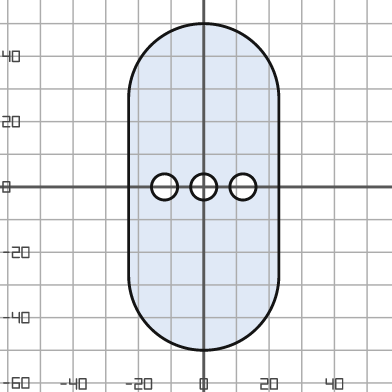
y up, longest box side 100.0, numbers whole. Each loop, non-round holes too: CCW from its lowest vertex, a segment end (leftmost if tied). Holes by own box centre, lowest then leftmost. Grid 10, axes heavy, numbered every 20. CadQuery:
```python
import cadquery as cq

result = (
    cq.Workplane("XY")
    .moveTo(-23.0, -27.0)
    .threePointArc((0.0, -50.0), (23.0, -27.0))
    .lineTo(23.0, 27.0)
    .threePointArc((0.0, 50.0), (-23.0, 27.0))
    .close()
    .moveTo(-12.0, 0.0)
    .circle(4.0)
    .moveTo(0.0, 0.0)
    .circle(4.0)
    .moveTo(12.0, 0.0)
    .circle(4.0)
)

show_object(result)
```